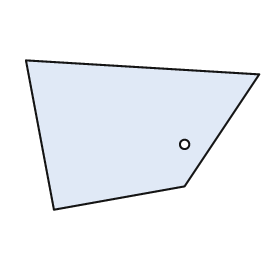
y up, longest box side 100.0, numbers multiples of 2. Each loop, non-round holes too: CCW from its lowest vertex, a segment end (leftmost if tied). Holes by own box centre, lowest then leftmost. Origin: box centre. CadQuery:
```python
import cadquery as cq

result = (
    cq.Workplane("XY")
    .moveTo(-38.0, -32.0)
    .lineTo(18.0, -22.0)
    .lineTo(50.0, 26.0)
    .lineTo(-50.0, 32.0)
    .close()
    .moveTo(18.0, -4.0)
    .circle(2.0)
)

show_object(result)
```